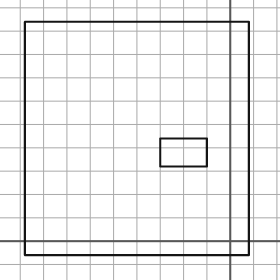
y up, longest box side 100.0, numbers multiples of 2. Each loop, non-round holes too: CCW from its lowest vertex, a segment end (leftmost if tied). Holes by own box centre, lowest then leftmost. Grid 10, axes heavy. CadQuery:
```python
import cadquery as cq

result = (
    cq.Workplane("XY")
    .moveTo(-88.0, -6.0)
    .lineTo(8.0, -6.0)
    .lineTo(8.0, 94.0)
    .lineTo(-88.0, 94.0)
    .close()
    .moveTo(-30.0, 32.0)
    .lineTo(-10.0, 32.0)
    .lineTo(-10.0, 44.0)
    .lineTo(-30.0, 44.0)
    .close()
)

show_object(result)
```